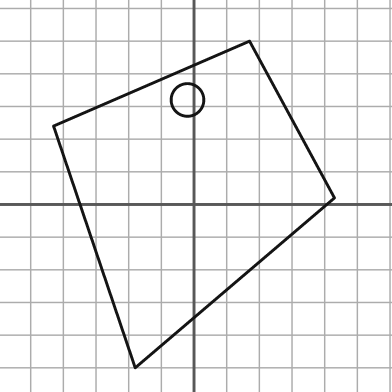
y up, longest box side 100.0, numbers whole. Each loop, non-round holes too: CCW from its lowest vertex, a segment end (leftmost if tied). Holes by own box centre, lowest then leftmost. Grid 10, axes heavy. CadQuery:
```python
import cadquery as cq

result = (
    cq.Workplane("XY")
    .moveTo(-18.0, -50.0)
    .lineTo(43.0, 2.0)
    .lineTo(17.0, 50.0)
    .lineTo(-43.0, 24.0)
    .close()
    .moveTo(-2.0, 32.0)
    .circle(5.0)
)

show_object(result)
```